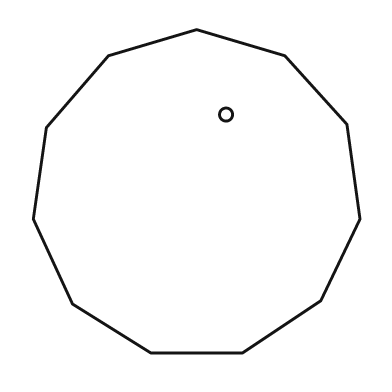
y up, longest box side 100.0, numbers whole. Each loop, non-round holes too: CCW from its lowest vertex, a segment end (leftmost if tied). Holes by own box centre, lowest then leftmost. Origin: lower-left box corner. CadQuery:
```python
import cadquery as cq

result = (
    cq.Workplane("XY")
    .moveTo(36.0, 0.0)
    .lineTo(64.0, 0.0)
    .lineTo(88.0, 16.0)
    .lineTo(100.0, 41.0)
    .lineTo(96.0, 70.0)
    .lineTo(77.0, 91.0)
    .lineTo(50.0, 99.0)
    .lineTo(23.0, 91.0)
    .lineTo(4.0, 69.0)
    .lineTo(0.0, 41.0)
    .lineTo(12.0, 15.0)
    .close()
    .moveTo(59.0, 73.0)
    .circle(2.0)
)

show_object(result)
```